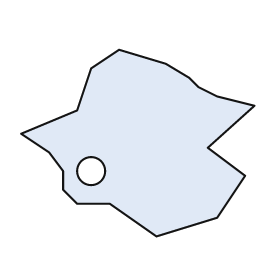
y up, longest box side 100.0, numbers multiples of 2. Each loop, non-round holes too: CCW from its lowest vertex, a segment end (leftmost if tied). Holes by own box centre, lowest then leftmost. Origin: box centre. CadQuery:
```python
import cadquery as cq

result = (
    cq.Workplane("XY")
    .moveTo(8.0, -40.0)
    .lineTo(34.0, -32.0)
    .lineTo(46.0, -14.0)
    .lineTo(30.0, -2.0)
    .lineTo(50.0, 16.0)
    .lineTo(34.0, 20.0)
    .lineTo(26.0, 24.0)
    .lineTo(22.0, 28.0)
    .lineTo(12.0, 34.0)
    .lineTo(-8.0, 40.0)
    .lineTo(-20.0, 32.0)
    .lineTo(-26.0, 14.0)
    .lineTo(-50.0, 4.0)
    .lineTo(-38.0, -4.0)
    .lineTo(-32.0, -12.0)
    .lineTo(-32.0, -20.0)
    .lineTo(-26.0, -26.0)
    .lineTo(-12.0, -26.0)
    .close()
    .moveTo(-20.0, -12.0)
    .circle(6.0)
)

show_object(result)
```